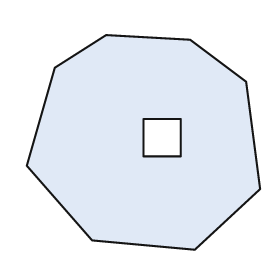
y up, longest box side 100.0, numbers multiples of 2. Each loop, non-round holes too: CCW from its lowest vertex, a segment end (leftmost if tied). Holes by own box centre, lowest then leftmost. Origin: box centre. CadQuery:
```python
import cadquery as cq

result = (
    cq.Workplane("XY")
    .moveTo(22.0, -46.0)
    .lineTo(50.0, -20.0)
    .lineTo(44.0, 26.0)
    .lineTo(20.0, 44.0)
    .lineTo(-16.0, 46.0)
    .lineTo(-38.0, 32.0)
    .lineTo(-50.0, -10.0)
    .lineTo(-22.0, -42.0)
    .close()
    .moveTo(0.0, -6.0)
    .lineTo(16.0, -6.0)
    .lineTo(16.0, 10.0)
    .lineTo(0.0, 10.0)
    .close()
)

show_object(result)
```